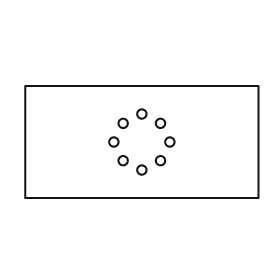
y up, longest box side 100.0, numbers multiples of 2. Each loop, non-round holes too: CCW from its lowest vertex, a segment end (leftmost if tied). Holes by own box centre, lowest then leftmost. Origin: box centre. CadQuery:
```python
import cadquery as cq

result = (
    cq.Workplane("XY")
    .moveTo(-50.0, -24.0)
    .lineTo(50.0, -24.0)
    .lineTo(50.0, 24.0)
    .lineTo(-50.0, 24.0)
    .close()
    .moveTo(0.0, -12.0)
    .circle(2.0)
    .moveTo(-8.0, -8.0)
    .circle(2.0)
    .moveTo(8.0, -8.0)
    .circle(2.0)
    .moveTo(-12.0, 0.0)
    .circle(2.0)
    .moveTo(12.0, 0.0)
    .circle(2.0)
    .moveTo(-8.0, 8.0)
    .circle(2.0)
    .moveTo(8.0, 8.0)
    .circle(2.0)
    .moveTo(0.0, 12.0)
    .circle(2.0)
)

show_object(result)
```